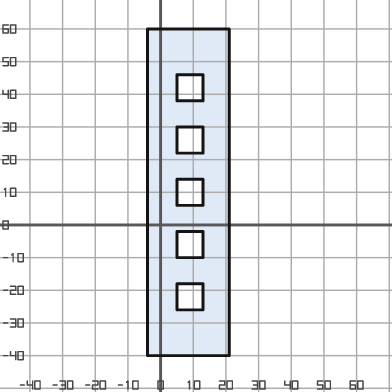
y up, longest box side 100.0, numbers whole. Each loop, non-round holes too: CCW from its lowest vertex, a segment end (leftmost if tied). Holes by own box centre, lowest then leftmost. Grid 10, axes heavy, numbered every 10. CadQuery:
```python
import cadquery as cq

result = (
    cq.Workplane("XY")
    .moveTo(-4.0, -40.0)
    .lineTo(21.0, -40.0)
    .lineTo(21.0, 60.0)
    .lineTo(-4.0, 60.0)
    .close()
    .moveTo(5.0, -26.0)
    .lineTo(13.0, -26.0)
    .lineTo(13.0, -18.0)
    .lineTo(5.0, -18.0)
    .close()
    .moveTo(5.0, -10.0)
    .lineTo(13.0, -10.0)
    .lineTo(13.0, -2.0)
    .lineTo(5.0, -2.0)
    .close()
    .moveTo(5.0, 6.0)
    .lineTo(13.0, 6.0)
    .lineTo(13.0, 14.0)
    .lineTo(5.0, 14.0)
    .close()
    .moveTo(5.0, 22.0)
    .lineTo(13.0, 22.0)
    .lineTo(13.0, 30.0)
    .lineTo(5.0, 30.0)
    .close()
    .moveTo(5.0, 38.0)
    .lineTo(13.0, 38.0)
    .lineTo(13.0, 46.0)
    .lineTo(5.0, 46.0)
    .close()
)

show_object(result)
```